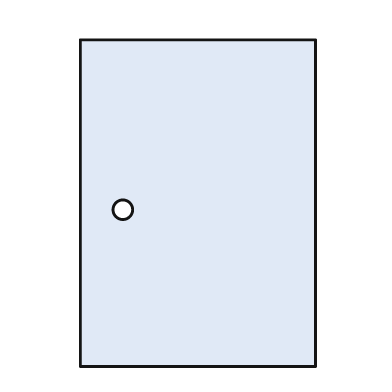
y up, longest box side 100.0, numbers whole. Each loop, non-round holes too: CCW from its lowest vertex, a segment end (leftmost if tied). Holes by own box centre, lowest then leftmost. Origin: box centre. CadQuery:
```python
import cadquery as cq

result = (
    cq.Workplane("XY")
    .moveTo(-36.0, -50.0)
    .lineTo(36.0, -50.0)
    .lineTo(36.0, 50.0)
    .lineTo(-36.0, 50.0)
    .close()
    .moveTo(-23.0, -2.0)
    .circle(3.0)
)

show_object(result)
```